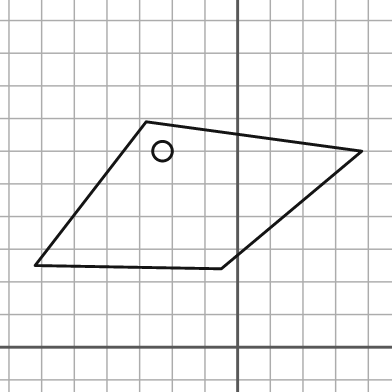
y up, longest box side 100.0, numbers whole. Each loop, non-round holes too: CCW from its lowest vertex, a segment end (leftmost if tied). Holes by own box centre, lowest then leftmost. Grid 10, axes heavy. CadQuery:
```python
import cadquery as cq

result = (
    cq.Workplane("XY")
    .moveTo(-5.0, 24.0)
    .lineTo(38.0, 60.0)
    .lineTo(-28.0, 69.0)
    .lineTo(-62.0, 25.0)
    .close()
    .moveTo(-23.0, 60.0)
    .circle(3.0)
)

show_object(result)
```